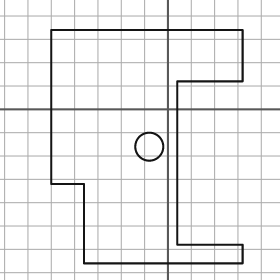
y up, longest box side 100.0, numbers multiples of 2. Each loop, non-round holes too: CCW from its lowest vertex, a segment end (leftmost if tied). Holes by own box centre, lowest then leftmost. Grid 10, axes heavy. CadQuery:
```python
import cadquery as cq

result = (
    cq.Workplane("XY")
    .moveTo(-36.0, -66.0)
    .lineTo(32.0, -66.0)
    .lineTo(32.0, -58.0)
    .lineTo(4.0, -58.0)
    .lineTo(4.0, 12.0)
    .lineTo(32.0, 12.0)
    .lineTo(32.0, 34.0)
    .lineTo(-50.0, 34.0)
    .lineTo(-50.0, -32.0)
    .lineTo(-36.0, -32.0)
    .close()
    .moveTo(-8.0, -16.0)
    .circle(6.0)
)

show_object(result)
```